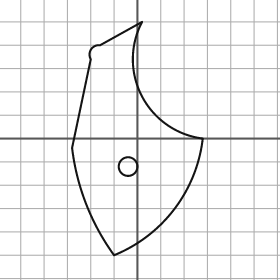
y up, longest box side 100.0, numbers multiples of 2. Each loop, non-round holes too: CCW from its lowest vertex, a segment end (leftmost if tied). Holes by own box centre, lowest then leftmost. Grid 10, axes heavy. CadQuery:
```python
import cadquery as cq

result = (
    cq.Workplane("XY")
    .moveTo(-10.0, -50.0)
    .threePointArc((16.0, -30.0), (28.0, 0.0))
    .threePointArc((2.0, 18.0), (2.0, 50.0))
    .lineTo(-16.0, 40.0)
    .threePointArc((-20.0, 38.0), (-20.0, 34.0))
    .lineTo(-28.0, -4.0)
    .threePointArc((-22.0, -28.0), (-10.0, -50.0))
    .close()
    .moveTo(-4.0, -12.0)
    .circle(4.0)
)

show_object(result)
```